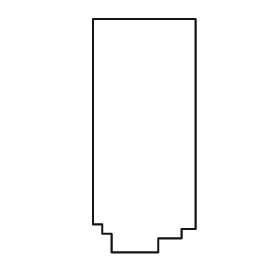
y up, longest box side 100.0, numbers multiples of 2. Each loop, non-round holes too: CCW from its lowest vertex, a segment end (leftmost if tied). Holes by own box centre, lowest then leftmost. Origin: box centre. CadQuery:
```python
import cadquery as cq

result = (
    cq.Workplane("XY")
    .moveTo(-14.0, -50.0)
    .lineTo(6.0, -50.0)
    .lineTo(6.0, -44.0)
    .lineTo(16.0, -44.0)
    .lineTo(16.0, -40.0)
    .lineTo(22.0, -40.0)
    .lineTo(22.0, 50.0)
    .lineTo(-22.0, 50.0)
    .lineTo(-22.0, -38.0)
    .lineTo(-18.0, -38.0)
    .lineTo(-18.0, -42.0)
    .lineTo(-14.0, -42.0)
    .close()
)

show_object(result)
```